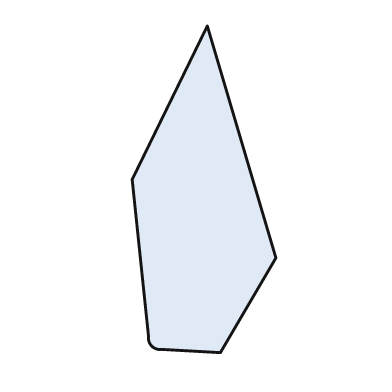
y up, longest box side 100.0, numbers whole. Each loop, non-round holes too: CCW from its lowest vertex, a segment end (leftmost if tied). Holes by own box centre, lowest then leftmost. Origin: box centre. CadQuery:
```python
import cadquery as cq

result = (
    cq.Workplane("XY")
    .moveTo(5.0, -50.0)
    .lineTo(22.0, -21.0)
    .lineTo(1.0, 50.0)
    .lineTo(-22.0, 3.0)
    .lineTo(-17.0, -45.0)
    .threePointArc((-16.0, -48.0), (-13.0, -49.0))
    .close()
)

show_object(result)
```